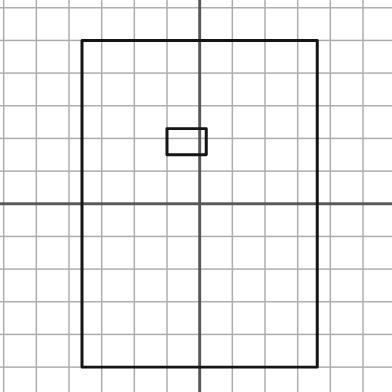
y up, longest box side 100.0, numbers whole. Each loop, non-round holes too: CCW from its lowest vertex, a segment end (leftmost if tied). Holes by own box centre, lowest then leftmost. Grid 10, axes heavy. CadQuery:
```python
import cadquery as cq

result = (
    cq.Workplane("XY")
    .moveTo(-36.0, -50.0)
    .lineTo(36.0, -50.0)
    .lineTo(36.0, 50.0)
    .lineTo(-36.0, 50.0)
    .close()
    .moveTo(-10.0, 15.0)
    .lineTo(2.0, 15.0)
    .lineTo(2.0, 23.0)
    .lineTo(-10.0, 23.0)
    .close()
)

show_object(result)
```